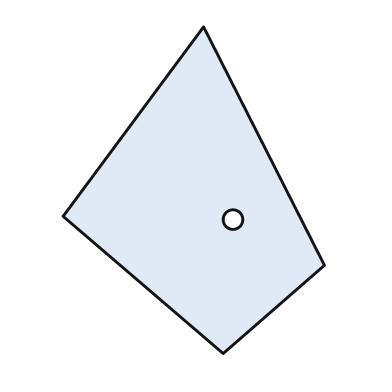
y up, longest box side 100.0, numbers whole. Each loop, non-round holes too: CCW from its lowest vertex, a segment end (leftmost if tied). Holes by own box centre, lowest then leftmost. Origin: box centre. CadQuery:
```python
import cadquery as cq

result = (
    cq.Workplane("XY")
    .moveTo(9.0, -50.0)
    .lineTo(40.0, -23.0)
    .lineTo(3.0, 50.0)
    .lineTo(-40.0, -8.0)
    .close()
    .moveTo(12.0, -9.0)
    .circle(3.0)
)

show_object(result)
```